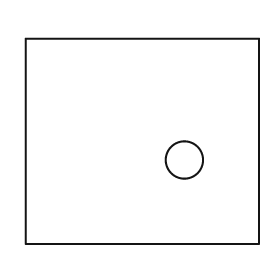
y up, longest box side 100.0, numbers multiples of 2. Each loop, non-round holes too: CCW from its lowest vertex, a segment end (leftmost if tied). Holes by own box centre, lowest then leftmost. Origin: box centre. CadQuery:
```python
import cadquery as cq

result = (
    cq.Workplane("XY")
    .moveTo(-50.0, -44.0)
    .lineTo(50.0, -44.0)
    .lineTo(50.0, 44.0)
    .lineTo(-50.0, 44.0)
    .close()
    .moveTo(18.0, -8.0)
    .circle(8.0)
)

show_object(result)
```